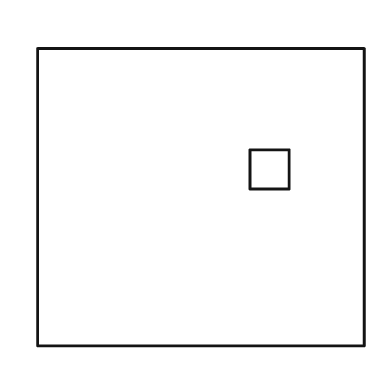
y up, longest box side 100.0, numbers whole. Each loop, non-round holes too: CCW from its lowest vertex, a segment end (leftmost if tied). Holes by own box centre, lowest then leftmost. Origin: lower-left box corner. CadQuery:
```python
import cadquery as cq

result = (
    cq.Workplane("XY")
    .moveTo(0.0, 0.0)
    .lineTo(100.0, 0.0)
    .lineTo(100.0, 91.0)
    .lineTo(0.0, 91.0)
    .close()
    .moveTo(65.0, 48.0)
    .lineTo(77.0, 48.0)
    .lineTo(77.0, 60.0)
    .lineTo(65.0, 60.0)
    .close()
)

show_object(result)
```